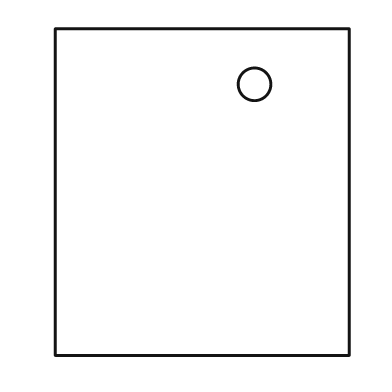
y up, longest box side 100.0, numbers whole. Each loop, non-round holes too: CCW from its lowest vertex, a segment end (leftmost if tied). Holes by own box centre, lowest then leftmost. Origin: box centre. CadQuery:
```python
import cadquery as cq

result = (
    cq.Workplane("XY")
    .moveTo(-45.0, -50.0)
    .lineTo(45.0, -50.0)
    .lineTo(45.0, 50.0)
    .lineTo(-45.0, 50.0)
    .close()
    .moveTo(16.0, 33.0)
    .circle(5.0)
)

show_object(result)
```